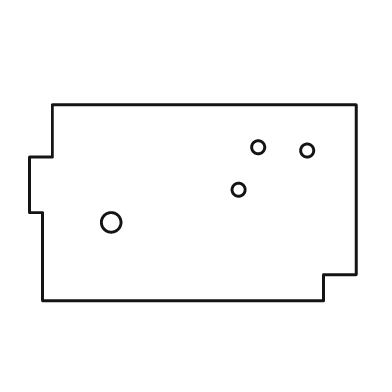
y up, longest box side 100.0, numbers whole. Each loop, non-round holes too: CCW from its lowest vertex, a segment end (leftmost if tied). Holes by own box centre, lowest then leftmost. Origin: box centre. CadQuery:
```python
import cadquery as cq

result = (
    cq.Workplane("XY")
    .moveTo(-46.0, -30.0)
    .lineTo(40.0, -30.0)
    .lineTo(40.0, -22.0)
    .lineTo(50.0, -22.0)
    .lineTo(50.0, 30.0)
    .lineTo(-43.0, 30.0)
    .lineTo(-43.0, 14.0)
    .lineTo(-50.0, 14.0)
    .lineTo(-50.0, -3.0)
    .lineTo(-46.0, -3.0)
    .close()
    .moveTo(-25.0, -6.0)
    .circle(3.0)
    .moveTo(14.0, 4.0)
    .circle(2.0)
    .moveTo(35.0, 16.0)
    .circle(2.0)
    .moveTo(20.0, 17.0)
    .circle(2.0)
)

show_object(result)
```